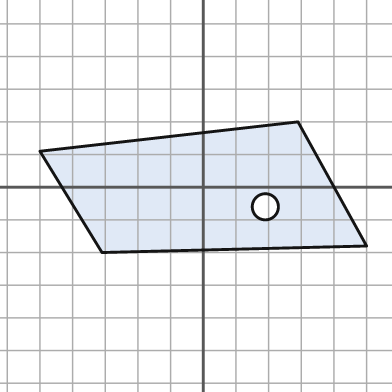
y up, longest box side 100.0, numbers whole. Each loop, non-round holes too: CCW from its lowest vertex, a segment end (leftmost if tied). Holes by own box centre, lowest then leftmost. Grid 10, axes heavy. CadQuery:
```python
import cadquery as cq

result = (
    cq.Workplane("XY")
    .moveTo(-31.0, -20.0)
    .lineTo(50.0, -18.0)
    .lineTo(29.0, 20.0)
    .lineTo(-50.0, 11.0)
    .close()
    .moveTo(19.0, -6.0)
    .circle(4.0)
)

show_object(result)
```